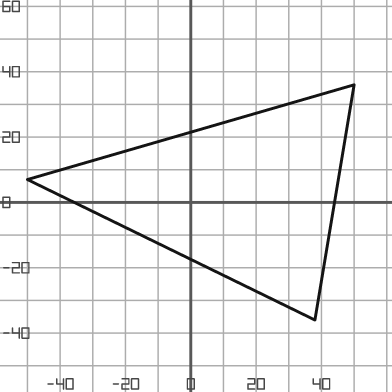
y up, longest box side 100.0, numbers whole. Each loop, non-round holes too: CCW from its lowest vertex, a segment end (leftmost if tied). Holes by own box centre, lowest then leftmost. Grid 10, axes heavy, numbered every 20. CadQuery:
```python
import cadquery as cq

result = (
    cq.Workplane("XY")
    .moveTo(38.0, -36.0)
    .lineTo(50.0, 36.0)
    .lineTo(-50.0, 7.0)
    .close()
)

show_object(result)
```